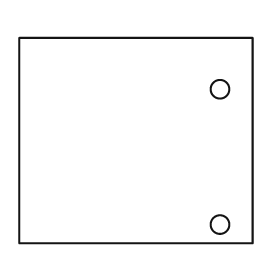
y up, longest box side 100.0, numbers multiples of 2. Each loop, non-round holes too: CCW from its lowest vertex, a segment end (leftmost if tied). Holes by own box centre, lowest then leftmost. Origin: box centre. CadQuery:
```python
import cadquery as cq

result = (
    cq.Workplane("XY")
    .moveTo(-50.0, -44.0)
    .lineTo(50.0, -44.0)
    .lineTo(50.0, 44.0)
    .lineTo(-50.0, 44.0)
    .close()
    .moveTo(36.0, -36.0)
    .circle(4.0)
    .moveTo(36.0, 22.0)
    .circle(4.0)
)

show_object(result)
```